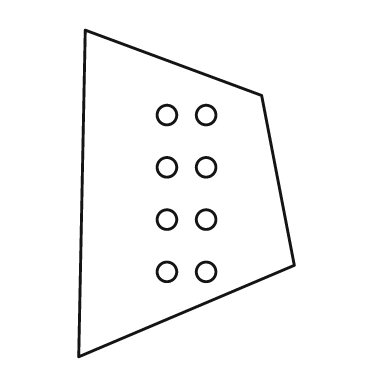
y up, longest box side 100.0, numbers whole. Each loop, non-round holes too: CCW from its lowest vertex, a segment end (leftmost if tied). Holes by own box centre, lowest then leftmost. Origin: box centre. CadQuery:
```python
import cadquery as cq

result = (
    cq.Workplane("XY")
    .moveTo(-33.0, -50.0)
    .lineTo(33.0, -22.0)
    .lineTo(23.0, 30.0)
    .lineTo(-31.0, 50.0)
    .close()
    .moveTo(-6.0, -24.0)
    .circle(3.0)
    .moveTo(6.0, -24.0)
    .circle(3.0)
    .moveTo(-6.0, -8.0)
    .circle(3.0)
    .moveTo(6.0, -8.0)
    .circle(3.0)
    .moveTo(-6.0, 8.0)
    .circle(3.0)
    .moveTo(6.0, 8.0)
    .circle(3.0)
    .moveTo(-6.0, 24.0)
    .circle(3.0)
    .moveTo(6.0, 24.0)
    .circle(3.0)
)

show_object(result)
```